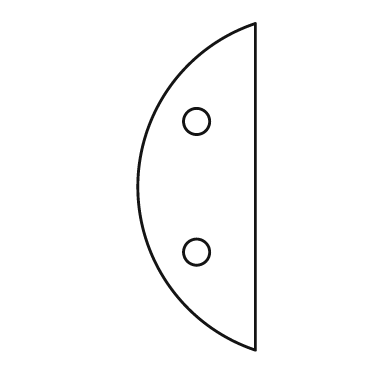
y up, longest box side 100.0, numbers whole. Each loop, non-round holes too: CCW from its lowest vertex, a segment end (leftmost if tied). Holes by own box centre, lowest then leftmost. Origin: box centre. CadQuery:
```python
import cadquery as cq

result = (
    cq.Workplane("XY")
    .moveTo(18.0, -50.0)
    .lineTo(18.0, 50.0)
    .threePointArc((-18.0, 0.0), (18.0, -50.0))
    .close()
    .moveTo(0.0, -20.0)
    .circle(4.0)
    .moveTo(0.0, 20.0)
    .circle(4.0)
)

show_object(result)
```